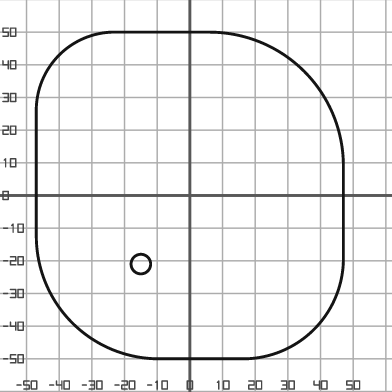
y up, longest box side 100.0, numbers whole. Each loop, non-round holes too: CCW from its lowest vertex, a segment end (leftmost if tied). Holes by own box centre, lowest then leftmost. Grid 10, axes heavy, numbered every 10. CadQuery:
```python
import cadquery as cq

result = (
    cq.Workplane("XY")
    .moveTo(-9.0, -50.0)
    .lineTo(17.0, -50.0)
    .threePointArc((38.0, -41.0), (47.0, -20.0))
    .lineTo(47.0, 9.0)
    .threePointArc((35.0, 38.0), (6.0, 50.0))
    .lineTo(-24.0, 50.0)
    .threePointArc((-40.0, 43.0), (-47.0, 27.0))
    .lineTo(-47.0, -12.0)
    .threePointArc((-36.0, -39.0), (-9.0, -50.0))
    .close()
    .moveTo(-15.0, -21.0)
    .circle(3.0)
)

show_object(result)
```